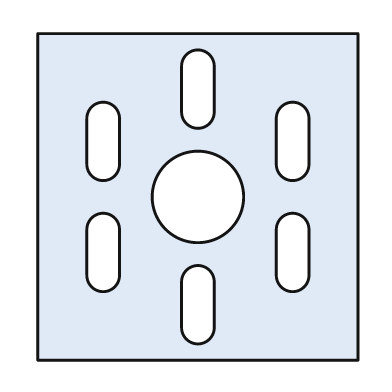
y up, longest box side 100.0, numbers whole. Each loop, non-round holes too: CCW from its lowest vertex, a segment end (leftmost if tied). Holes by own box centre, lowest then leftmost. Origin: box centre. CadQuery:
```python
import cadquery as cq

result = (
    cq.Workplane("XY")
    .moveTo(-49.0, -50.0)
    .lineTo(49.0, -50.0)
    .lineTo(49.0, 50.0)
    .lineTo(-49.0, 50.0)
    .close()
    .moveTo(-5.0, -40.0)
    .threePointArc((0.0, -45.0), (5.0, -40.0))
    .lineTo(5.0, -26.0)
    .threePointArc((0.0, -21.0), (-5.0, -26.0))
    .close()
    .moveTo(-34.0, -24.0)
    .threePointArc((-29.0, -29.0), (-24.0, -24.0))
    .lineTo(-24.0, -10.0)
    .threePointArc((-29.0, -5.0), (-34.0, -10.0))
    .close()
    .moveTo(24.0, -24.0)
    .threePointArc((29.0, -29.0), (34.0, -24.0))
    .lineTo(34.0, -10.0)
    .threePointArc((29.0, -5.0), (24.0, -10.0))
    .close()
    .moveTo(0.0, 0.0)
    .circle(14.0)
    .moveTo(-34.0, 10.0)
    .threePointArc((-29.0, 5.0), (-24.0, 10.0))
    .lineTo(-24.0, 24.0)
    .threePointArc((-29.0, 29.0), (-34.0, 24.0))
    .close()
    .moveTo(24.0, 10.0)
    .threePointArc((29.0, 5.0), (34.0, 10.0))
    .lineTo(34.0, 24.0)
    .threePointArc((29.0, 29.0), (24.0, 24.0))
    .close()
    .moveTo(-5.0, 26.0)
    .threePointArc((0.0, 21.0), (5.0, 26.0))
    .lineTo(5.0, 40.0)
    .threePointArc((0.0, 45.0), (-5.0, 40.0))
    .close()
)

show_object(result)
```